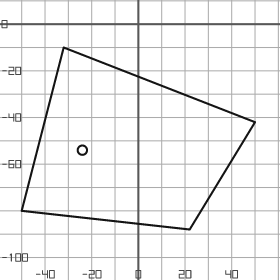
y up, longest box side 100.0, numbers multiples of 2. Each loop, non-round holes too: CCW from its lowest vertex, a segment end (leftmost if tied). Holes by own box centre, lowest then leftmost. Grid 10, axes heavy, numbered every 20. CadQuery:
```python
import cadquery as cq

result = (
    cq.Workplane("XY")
    .moveTo(22.0, -88.0)
    .lineTo(50.0, -42.0)
    .lineTo(-32.0, -10.0)
    .lineTo(-50.0, -80.0)
    .close()
    .moveTo(-24.0, -54.0)
    .circle(2.0)
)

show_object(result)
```